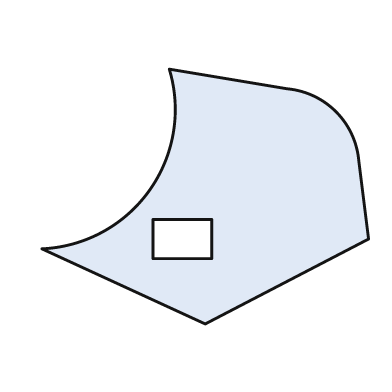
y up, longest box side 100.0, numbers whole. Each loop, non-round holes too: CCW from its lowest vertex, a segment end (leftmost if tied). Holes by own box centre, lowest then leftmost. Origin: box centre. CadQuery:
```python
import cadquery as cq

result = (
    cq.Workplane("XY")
    .moveTo(0.0, -39.0)
    .lineTo(50.0, -13.0)
    .lineTo(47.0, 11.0)
    .threePointArc((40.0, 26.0), (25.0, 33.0))
    .lineTo(-11.0, 39.0)
    .threePointArc((-17.0, 2.0), (-50.0, -16.0))
    .close()
    .moveTo(-16.0, -19.0)
    .lineTo(2.0, -19.0)
    .lineTo(2.0, -7.0)
    .lineTo(-16.0, -7.0)
    .close()
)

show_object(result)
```